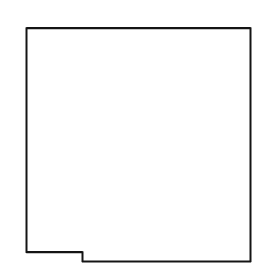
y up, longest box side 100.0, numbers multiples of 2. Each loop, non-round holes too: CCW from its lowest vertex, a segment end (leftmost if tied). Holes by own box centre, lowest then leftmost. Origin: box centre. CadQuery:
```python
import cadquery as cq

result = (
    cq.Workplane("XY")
    .moveTo(-24.0, -50.0)
    .lineTo(48.0, -50.0)
    .lineTo(48.0, 50.0)
    .lineTo(-48.0, 50.0)
    .lineTo(-48.0, -46.0)
    .lineTo(-24.0, -46.0)
    .close()
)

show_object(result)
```